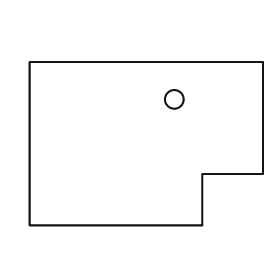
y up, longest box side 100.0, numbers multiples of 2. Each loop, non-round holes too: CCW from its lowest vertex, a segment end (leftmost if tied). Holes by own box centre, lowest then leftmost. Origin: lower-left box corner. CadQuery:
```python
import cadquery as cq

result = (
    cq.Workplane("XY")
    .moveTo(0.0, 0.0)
    .lineTo(74.0, 0.0)
    .lineTo(74.0, 22.0)
    .lineTo(100.0, 22.0)
    .lineTo(100.0, 70.0)
    .lineTo(0.0, 70.0)
    .close()
    .moveTo(62.0, 54.0)
    .circle(4.0)
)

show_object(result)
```